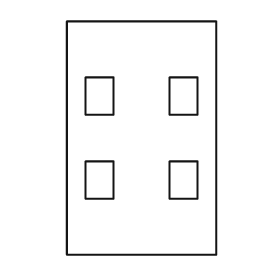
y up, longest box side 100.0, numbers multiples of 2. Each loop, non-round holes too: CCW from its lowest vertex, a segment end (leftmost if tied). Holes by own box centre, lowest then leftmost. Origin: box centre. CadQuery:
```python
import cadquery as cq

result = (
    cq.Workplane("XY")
    .moveTo(-32.0, -50.0)
    .lineTo(32.0, -50.0)
    .lineTo(32.0, 50.0)
    .lineTo(-32.0, 50.0)
    .close()
    .moveTo(-24.0, -26.0)
    .lineTo(-12.0, -26.0)
    .lineTo(-12.0, -10.0)
    .lineTo(-24.0, -10.0)
    .close()
    .moveTo(12.0, -26.0)
    .lineTo(24.0, -26.0)
    .lineTo(24.0, -10.0)
    .lineTo(12.0, -10.0)
    .close()
    .moveTo(-24.0, 10.0)
    .lineTo(-12.0, 10.0)
    .lineTo(-12.0, 26.0)
    .lineTo(-24.0, 26.0)
    .close()
    .moveTo(12.0, 10.0)
    .lineTo(24.0, 10.0)
    .lineTo(24.0, 26.0)
    .lineTo(12.0, 26.0)
    .close()
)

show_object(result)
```